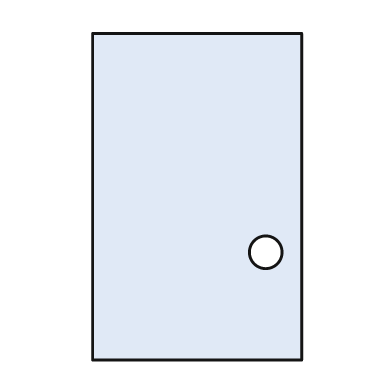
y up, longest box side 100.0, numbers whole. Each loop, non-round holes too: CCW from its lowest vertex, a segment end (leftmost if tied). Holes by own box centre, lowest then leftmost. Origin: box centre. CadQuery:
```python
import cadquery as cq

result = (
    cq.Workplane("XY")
    .moveTo(-32.0, -50.0)
    .lineTo(32.0, -50.0)
    .lineTo(32.0, 50.0)
    .lineTo(-32.0, 50.0)
    .close()
    .moveTo(21.0, -17.0)
    .circle(5.0)
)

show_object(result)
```